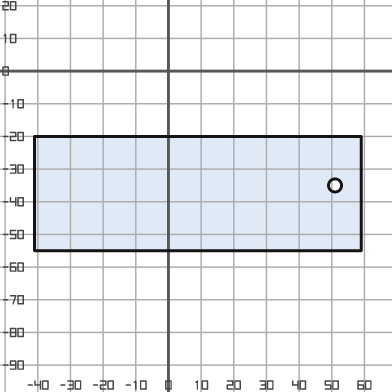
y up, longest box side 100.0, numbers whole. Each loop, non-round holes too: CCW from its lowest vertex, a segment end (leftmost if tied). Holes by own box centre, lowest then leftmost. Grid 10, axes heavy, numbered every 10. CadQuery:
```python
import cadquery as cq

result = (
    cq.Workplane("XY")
    .moveTo(-41.0, -55.0)
    .lineTo(59.0, -55.0)
    .lineTo(59.0, -20.0)
    .lineTo(-41.0, -20.0)
    .close()
    .moveTo(51.0, -35.0)
    .circle(2.0)
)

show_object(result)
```